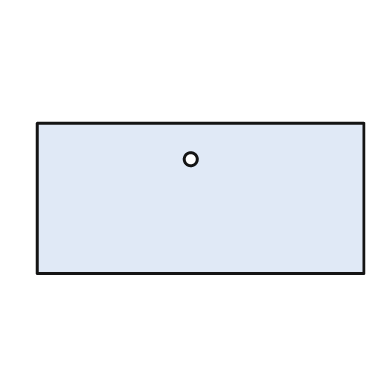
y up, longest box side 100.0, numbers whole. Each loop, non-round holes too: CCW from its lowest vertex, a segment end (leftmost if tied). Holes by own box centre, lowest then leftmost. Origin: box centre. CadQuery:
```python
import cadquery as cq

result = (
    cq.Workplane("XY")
    .moveTo(-50.0, -23.0)
    .lineTo(50.0, -23.0)
    .lineTo(50.0, 23.0)
    .lineTo(-50.0, 23.0)
    .close()
    .moveTo(-3.0, 12.0)
    .circle(2.0)
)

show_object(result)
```